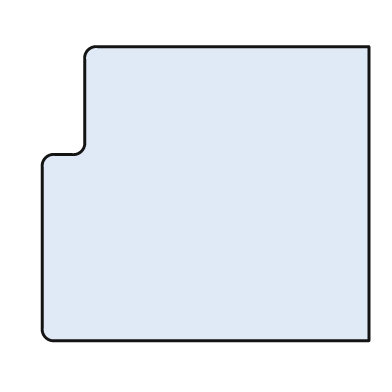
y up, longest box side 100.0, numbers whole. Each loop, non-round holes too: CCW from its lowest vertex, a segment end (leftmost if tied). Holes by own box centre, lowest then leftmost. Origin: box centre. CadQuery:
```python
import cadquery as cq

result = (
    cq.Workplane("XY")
    .moveTo(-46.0, -45.0)
    .lineTo(50.0, -45.0)
    .lineTo(50.0, 45.0)
    .lineTo(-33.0, 45.0)
    .threePointArc((-36.0, 44.0), (-37.0, 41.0))
    .lineTo(-37.0, 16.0)
    .threePointArc((-38.0, 13.0), (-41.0, 12.0))
    .lineTo(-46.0, 12.0)
    .threePointArc((-49.0, 11.0), (-50.0, 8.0))
    .lineTo(-50.0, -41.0)
    .threePointArc((-49.0, -44.0), (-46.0, -45.0))
    .close()
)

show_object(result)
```